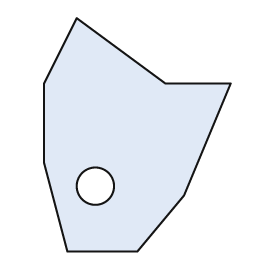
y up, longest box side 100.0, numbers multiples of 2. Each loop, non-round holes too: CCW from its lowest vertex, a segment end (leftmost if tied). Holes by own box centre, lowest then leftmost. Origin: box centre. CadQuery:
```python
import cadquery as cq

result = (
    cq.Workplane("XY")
    .moveTo(-30.0, -50.0)
    .lineTo(0.0, -50.0)
    .lineTo(20.0, -26.0)
    .lineTo(40.0, 22.0)
    .lineTo(12.0, 22.0)
    .lineTo(-26.0, 50.0)
    .lineTo(-40.0, 22.0)
    .lineTo(-40.0, -12.0)
    .close()
    .moveTo(-18.0, -22.0)
    .circle(8.0)
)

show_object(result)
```